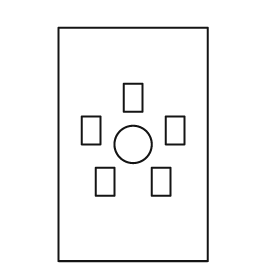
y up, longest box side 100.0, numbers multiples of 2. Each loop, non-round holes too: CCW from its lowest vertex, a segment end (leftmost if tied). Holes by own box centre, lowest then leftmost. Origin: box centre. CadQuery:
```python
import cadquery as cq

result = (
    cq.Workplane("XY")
    .moveTo(-32.0, -50.0)
    .lineTo(32.0, -50.0)
    .lineTo(32.0, 50.0)
    .lineTo(-32.0, 50.0)
    .close()
    .moveTo(-16.0, -22.0)
    .lineTo(-8.0, -22.0)
    .lineTo(-8.0, -10.0)
    .lineTo(-16.0, -10.0)
    .close()
    .moveTo(8.0, -22.0)
    .lineTo(16.0, -22.0)
    .lineTo(16.0, -10.0)
    .lineTo(8.0, -10.0)
    .close()
    .moveTo(0.0, 0.0)
    .circle(8.0)
    .moveTo(-22.0, 0.0)
    .lineTo(-14.0, 0.0)
    .lineTo(-14.0, 12.0)
    .lineTo(-22.0, 12.0)
    .close()
    .moveTo(14.0, 0.0)
    .lineTo(22.0, 0.0)
    .lineTo(22.0, 12.0)
    .lineTo(14.0, 12.0)
    .close()
    .moveTo(-4.0, 14.0)
    .lineTo(4.0, 14.0)
    .lineTo(4.0, 26.0)
    .lineTo(-4.0, 26.0)
    .close()
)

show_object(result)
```